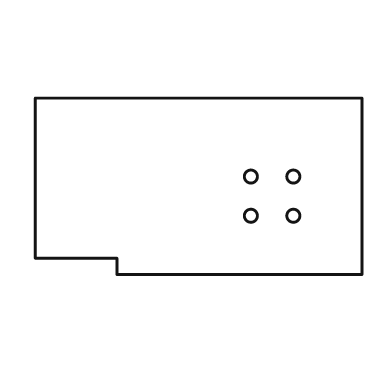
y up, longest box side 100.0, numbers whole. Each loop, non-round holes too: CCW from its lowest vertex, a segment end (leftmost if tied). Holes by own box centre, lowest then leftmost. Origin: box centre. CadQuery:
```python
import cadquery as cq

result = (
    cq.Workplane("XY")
    .moveTo(-25.0, -27.0)
    .lineTo(50.0, -27.0)
    .lineTo(50.0, 27.0)
    .lineTo(-50.0, 27.0)
    .lineTo(-50.0, -22.0)
    .lineTo(-25.0, -22.0)
    .close()
    .moveTo(16.0, -9.0)
    .circle(2.0)
    .moveTo(29.0, -9.0)
    .circle(2.0)
    .moveTo(16.0, 3.0)
    .circle(2.0)
    .moveTo(29.0, 3.0)
    .circle(2.0)
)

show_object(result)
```